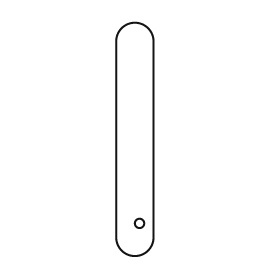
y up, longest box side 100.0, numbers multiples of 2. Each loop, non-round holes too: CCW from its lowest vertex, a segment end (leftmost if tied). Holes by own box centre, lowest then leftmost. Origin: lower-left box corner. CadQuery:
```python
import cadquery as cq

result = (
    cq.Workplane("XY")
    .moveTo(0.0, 8.0)
    .threePointArc((8.0, 0.0), (16.0, 8.0))
    .lineTo(16.0, 92.0)
    .threePointArc((8.0, 100.0), (0.0, 92.0))
    .close()
    .moveTo(10.0, 14.0)
    .circle(2.0)
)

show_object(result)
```